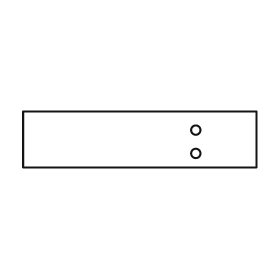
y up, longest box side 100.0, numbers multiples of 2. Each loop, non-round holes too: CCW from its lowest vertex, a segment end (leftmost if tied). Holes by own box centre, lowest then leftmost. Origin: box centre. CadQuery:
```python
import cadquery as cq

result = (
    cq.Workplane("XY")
    .moveTo(-50.0, -12.0)
    .lineTo(50.0, -12.0)
    .lineTo(50.0, 12.0)
    .lineTo(-50.0, 12.0)
    .close()
    .moveTo(24.0, -6.0)
    .circle(2.0)
    .moveTo(24.0, 4.0)
    .circle(2.0)
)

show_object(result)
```